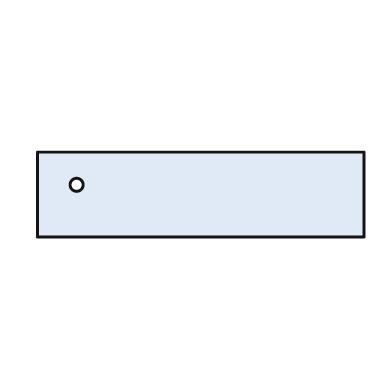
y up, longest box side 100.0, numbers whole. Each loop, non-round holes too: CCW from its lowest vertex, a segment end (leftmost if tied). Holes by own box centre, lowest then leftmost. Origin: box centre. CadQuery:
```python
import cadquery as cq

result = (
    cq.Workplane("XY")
    .moveTo(-50.0, -13.0)
    .lineTo(50.0, -13.0)
    .lineTo(50.0, 13.0)
    .lineTo(-50.0, 13.0)
    .close()
    .moveTo(-38.0, 3.0)
    .circle(2.0)
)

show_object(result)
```